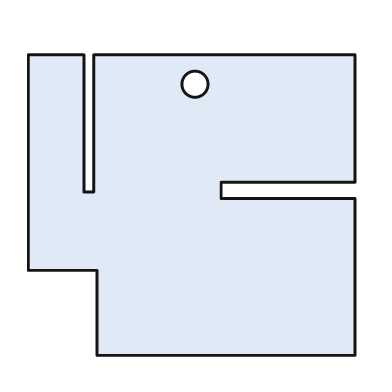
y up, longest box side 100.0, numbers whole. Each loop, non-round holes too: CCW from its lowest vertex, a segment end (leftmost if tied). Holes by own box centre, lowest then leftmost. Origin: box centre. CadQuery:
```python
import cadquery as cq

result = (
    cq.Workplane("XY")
    .moveTo(-29.0, -46.0)
    .lineTo(50.0, -46.0)
    .lineTo(50.0, 2.0)
    .lineTo(9.0, 2.0)
    .lineTo(9.0, 7.0)
    .lineTo(50.0, 7.0)
    .lineTo(50.0, 46.0)
    .lineTo(-30.0, 46.0)
    .lineTo(-30.0, 4.0)
    .lineTo(-33.0, 4.0)
    .lineTo(-33.0, 46.0)
    .lineTo(-50.0, 46.0)
    .lineTo(-50.0, -20.0)
    .lineTo(-29.0, -20.0)
    .close()
    .moveTo(1.0, 37.0)
    .circle(4.0)
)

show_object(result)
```